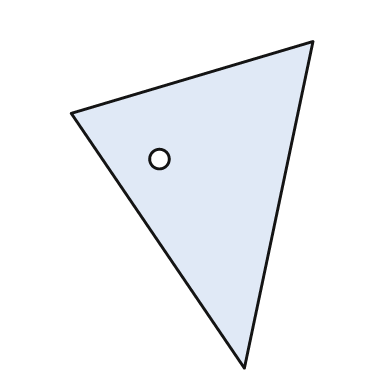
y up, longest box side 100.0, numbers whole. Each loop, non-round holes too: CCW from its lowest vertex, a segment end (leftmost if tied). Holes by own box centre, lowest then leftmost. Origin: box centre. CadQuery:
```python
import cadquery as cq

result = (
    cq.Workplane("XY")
    .moveTo(16.0, -50.0)
    .lineTo(37.0, 50.0)
    .lineTo(-37.0, 28.0)
    .close()
    .moveTo(-10.0, 14.0)
    .circle(3.0)
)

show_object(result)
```